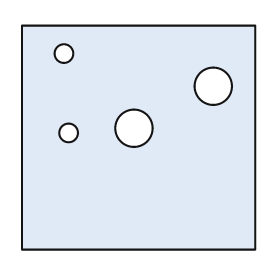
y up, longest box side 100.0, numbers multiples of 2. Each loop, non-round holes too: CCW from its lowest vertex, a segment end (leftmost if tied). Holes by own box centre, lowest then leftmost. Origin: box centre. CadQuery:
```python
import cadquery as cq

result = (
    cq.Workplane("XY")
    .moveTo(-50.0, -48.0)
    .lineTo(50.0, -48.0)
    .lineTo(50.0, 48.0)
    .lineTo(-50.0, 48.0)
    .close()
    .moveTo(-30.0, 2.0)
    .circle(4.0)
    .moveTo(-2.0, 4.0)
    .circle(8.0)
    .moveTo(32.0, 22.0)
    .circle(8.0)
    .moveTo(-32.0, 36.0)
    .circle(4.0)
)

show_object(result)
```